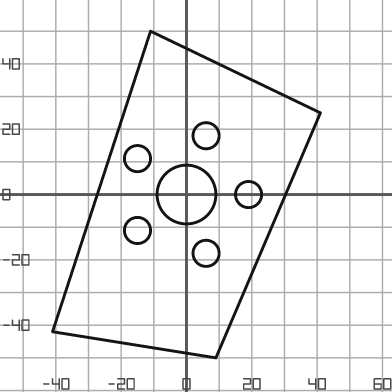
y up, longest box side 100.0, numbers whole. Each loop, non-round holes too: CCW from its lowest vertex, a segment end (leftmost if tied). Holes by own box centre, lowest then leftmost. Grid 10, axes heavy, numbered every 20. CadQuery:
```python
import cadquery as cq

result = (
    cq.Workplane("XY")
    .moveTo(9.0, -50.0)
    .lineTo(41.0, 25.0)
    .lineTo(-11.0, 50.0)
    .lineTo(-41.0, -42.0)
    .close()
    .moveTo(6.0, -18.0)
    .circle(4.0)
    .moveTo(-15.0, -11.0)
    .circle(4.0)
    .moveTo(0.0, 0.0)
    .circle(9.0)
    .moveTo(19.0, 0.0)
    .circle(4.0)
    .moveTo(-15.0, 11.0)
    .circle(4.0)
    .moveTo(6.0, 18.0)
    .circle(4.0)
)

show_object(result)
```